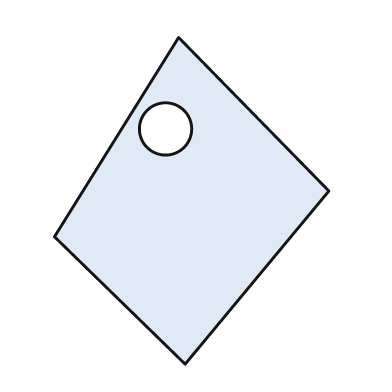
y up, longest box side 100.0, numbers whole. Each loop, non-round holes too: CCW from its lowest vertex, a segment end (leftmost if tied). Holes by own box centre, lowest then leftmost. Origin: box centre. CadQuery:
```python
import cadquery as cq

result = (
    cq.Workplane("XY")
    .moveTo(-2.0, -50.0)
    .lineTo(42.0, 3.0)
    .lineTo(-4.0, 50.0)
    .lineTo(-42.0, -11.0)
    .close()
    .moveTo(-8.0, 22.0)
    .circle(8.0)
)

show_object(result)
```